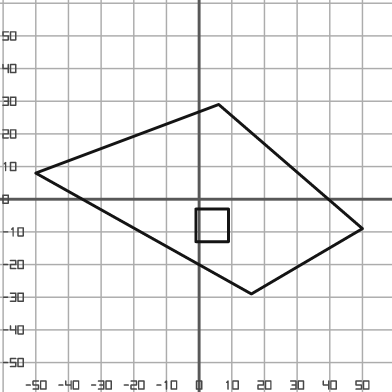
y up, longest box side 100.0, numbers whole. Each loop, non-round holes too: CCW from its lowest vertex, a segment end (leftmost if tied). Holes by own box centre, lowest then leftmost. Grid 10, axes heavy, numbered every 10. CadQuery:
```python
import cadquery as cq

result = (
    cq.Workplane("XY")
    .moveTo(16.0, -29.0)
    .lineTo(50.0, -9.0)
    .lineTo(6.0, 29.0)
    .lineTo(-50.0, 8.0)
    .close()
    .moveTo(-1.0, -13.0)
    .lineTo(9.0, -13.0)
    .lineTo(9.0, -3.0)
    .lineTo(-1.0, -3.0)
    .close()
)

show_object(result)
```